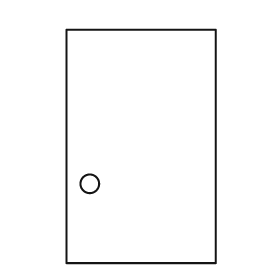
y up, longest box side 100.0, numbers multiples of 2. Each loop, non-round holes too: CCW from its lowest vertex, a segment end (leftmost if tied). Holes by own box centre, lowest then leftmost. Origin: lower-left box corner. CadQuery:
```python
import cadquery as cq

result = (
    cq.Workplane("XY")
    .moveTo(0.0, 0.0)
    .lineTo(64.0, 0.0)
    .lineTo(64.0, 100.0)
    .lineTo(0.0, 100.0)
    .close()
    .moveTo(10.0, 34.0)
    .circle(4.0)
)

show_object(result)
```